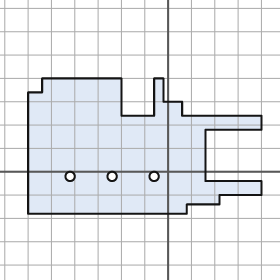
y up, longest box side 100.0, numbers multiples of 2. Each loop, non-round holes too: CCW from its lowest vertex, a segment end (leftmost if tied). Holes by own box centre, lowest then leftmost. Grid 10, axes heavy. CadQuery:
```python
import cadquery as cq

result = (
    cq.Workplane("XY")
    .moveTo(-60.0, -18.0)
    .lineTo(8.0, -18.0)
    .lineTo(8.0, -14.0)
    .lineTo(22.0, -14.0)
    .lineTo(22.0, -10.0)
    .lineTo(40.0, -10.0)
    .lineTo(40.0, -4.0)
    .lineTo(16.0, -4.0)
    .lineTo(16.0, 18.0)
    .lineTo(40.0, 18.0)
    .lineTo(40.0, 24.0)
    .lineTo(6.0, 24.0)
    .lineTo(6.0, 30.0)
    .lineTo(-2.0, 30.0)
    .lineTo(-2.0, 40.0)
    .lineTo(-6.0, 40.0)
    .lineTo(-6.0, 24.0)
    .lineTo(-20.0, 24.0)
    .lineTo(-20.0, 40.0)
    .lineTo(-54.0, 40.0)
    .lineTo(-54.0, 34.0)
    .lineTo(-60.0, 34.0)
    .close()
    .moveTo(-42.0, -2.0)
    .circle(2.0)
    .moveTo(-24.0, -2.0)
    .circle(2.0)
    .moveTo(-6.0, -2.0)
    .circle(2.0)
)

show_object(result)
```